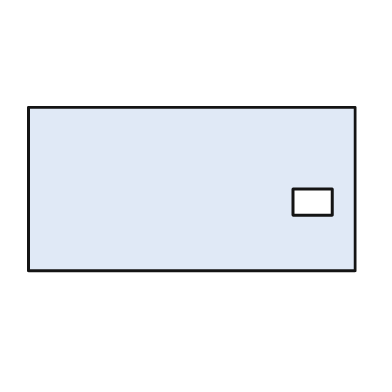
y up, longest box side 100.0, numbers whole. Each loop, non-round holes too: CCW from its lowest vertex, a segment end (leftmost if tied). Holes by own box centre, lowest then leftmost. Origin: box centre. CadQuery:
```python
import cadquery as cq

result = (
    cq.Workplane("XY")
    .moveTo(-50.0, -25.0)
    .lineTo(50.0, -25.0)
    .lineTo(50.0, 25.0)
    .lineTo(-50.0, 25.0)
    .close()
    .moveTo(31.0, -8.0)
    .lineTo(43.0, -8.0)
    .lineTo(43.0, 0.0)
    .lineTo(31.0, 0.0)
    .close()
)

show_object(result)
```